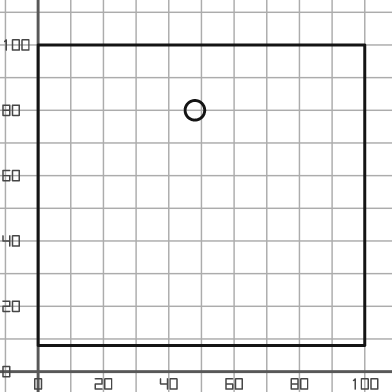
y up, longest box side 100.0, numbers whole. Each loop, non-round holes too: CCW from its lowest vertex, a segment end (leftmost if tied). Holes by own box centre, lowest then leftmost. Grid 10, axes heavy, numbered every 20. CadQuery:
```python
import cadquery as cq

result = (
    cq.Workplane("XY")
    .moveTo(0.0, 8.0)
    .lineTo(100.0, 8.0)
    .lineTo(100.0, 100.0)
    .lineTo(0.0, 100.0)
    .close()
    .moveTo(48.0, 80.0)
    .circle(3.0)
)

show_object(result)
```